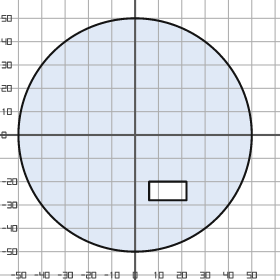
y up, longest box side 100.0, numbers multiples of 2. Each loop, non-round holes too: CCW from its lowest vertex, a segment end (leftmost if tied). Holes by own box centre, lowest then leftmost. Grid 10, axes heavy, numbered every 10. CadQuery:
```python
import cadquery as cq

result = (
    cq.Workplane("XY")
    .moveTo(0.0, 0.0)
    .circle(50.0)
    .moveTo(6.0, -28.0)
    .lineTo(22.0, -28.0)
    .lineTo(22.0, -20.0)
    .lineTo(6.0, -20.0)
    .close()
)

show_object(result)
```